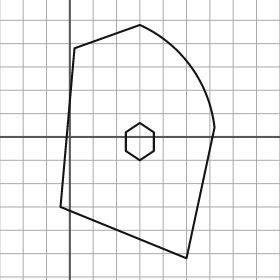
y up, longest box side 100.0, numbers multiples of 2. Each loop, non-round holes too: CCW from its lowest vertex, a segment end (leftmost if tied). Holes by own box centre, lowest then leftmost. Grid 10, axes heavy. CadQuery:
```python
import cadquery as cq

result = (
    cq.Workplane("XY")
    .moveTo(50.0, -52.0)
    .lineTo(62.0, 4.0)
    .threePointArc((52.0, 30.0), (30.0, 48.0))
    .lineTo(2.0, 38.0)
    .lineTo(-4.0, -30.0)
    .close()
    .moveTo(30.0, -10.0)
    .lineTo(36.0, -6.0)
    .lineTo(36.0, 2.0)
    .lineTo(30.0, 6.0)
    .lineTo(24.0, 2.0)
    .lineTo(24.0, -6.0)
    .close()
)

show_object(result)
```